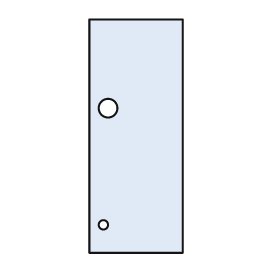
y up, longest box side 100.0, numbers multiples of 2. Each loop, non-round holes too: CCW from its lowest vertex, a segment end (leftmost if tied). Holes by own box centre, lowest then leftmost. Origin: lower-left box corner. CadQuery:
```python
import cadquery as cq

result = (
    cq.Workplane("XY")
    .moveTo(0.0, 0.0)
    .lineTo(40.0, 0.0)
    .lineTo(40.0, 100.0)
    .lineTo(0.0, 100.0)
    .close()
    .moveTo(6.0, 12.0)
    .circle(2.0)
    .moveTo(8.0, 62.0)
    .circle(4.0)
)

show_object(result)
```